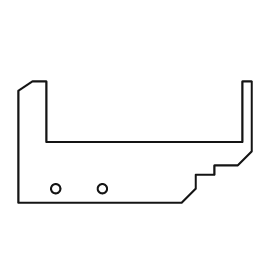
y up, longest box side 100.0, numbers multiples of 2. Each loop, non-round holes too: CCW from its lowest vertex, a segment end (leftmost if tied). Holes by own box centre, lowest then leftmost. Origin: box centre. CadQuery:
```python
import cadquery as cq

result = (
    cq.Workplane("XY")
    .moveTo(-50.0, -26.0)
    .lineTo(20.0, -26.0)
    .lineTo(26.0, -20.0)
    .lineTo(26.0, -14.0)
    .lineTo(34.0, -14.0)
    .lineTo(34.0, -10.0)
    .lineTo(44.0, -10.0)
    .lineTo(50.0, -4.0)
    .lineTo(50.0, 26.0)
    .lineTo(46.0, 26.0)
    .lineTo(46.0, 0.0)
    .lineTo(-38.0, 0.0)
    .lineTo(-38.0, 26.0)
    .lineTo(-44.0, 26.0)
    .lineTo(-50.0, 22.0)
    .close()
    .moveTo(-34.0, -20.0)
    .circle(2.0)
    .moveTo(-14.0, -20.0)
    .circle(2.0)
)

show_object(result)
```